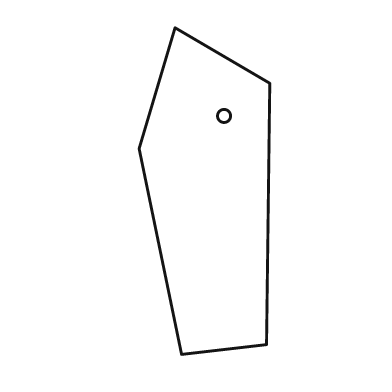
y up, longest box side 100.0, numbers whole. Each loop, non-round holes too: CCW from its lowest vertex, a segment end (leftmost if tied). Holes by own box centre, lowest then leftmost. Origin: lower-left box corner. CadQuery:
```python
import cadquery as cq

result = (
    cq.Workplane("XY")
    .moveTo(13.0, 0.0)
    .lineTo(39.0, 3.0)
    .lineTo(40.0, 83.0)
    .lineTo(11.0, 100.0)
    .lineTo(0.0, 63.0)
    .close()
    .moveTo(26.0, 73.0)
    .circle(2.0)
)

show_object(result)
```